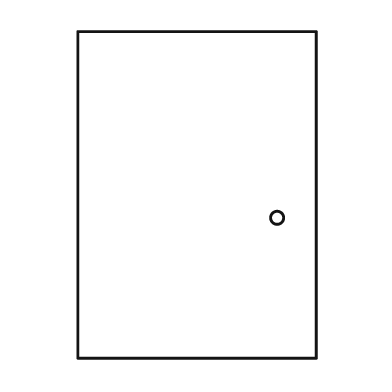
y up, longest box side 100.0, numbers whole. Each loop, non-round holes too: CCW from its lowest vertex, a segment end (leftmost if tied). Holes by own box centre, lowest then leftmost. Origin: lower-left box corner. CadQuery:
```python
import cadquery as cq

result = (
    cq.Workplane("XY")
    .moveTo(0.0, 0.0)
    .lineTo(73.0, 0.0)
    .lineTo(73.0, 100.0)
    .lineTo(0.0, 100.0)
    .close()
    .moveTo(61.0, 43.0)
    .circle(2.0)
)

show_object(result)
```